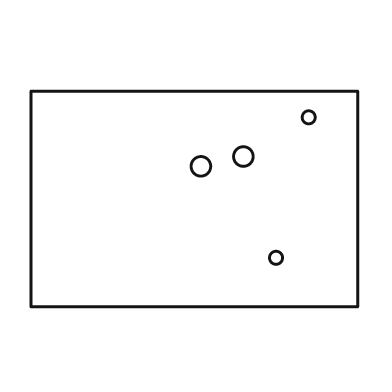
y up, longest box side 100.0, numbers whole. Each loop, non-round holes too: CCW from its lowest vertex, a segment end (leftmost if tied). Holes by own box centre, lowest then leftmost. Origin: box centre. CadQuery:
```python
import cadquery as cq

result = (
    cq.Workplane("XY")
    .moveTo(-50.0, -33.0)
    .lineTo(50.0, -33.0)
    .lineTo(50.0, 33.0)
    .lineTo(-50.0, 33.0)
    .close()
    .moveTo(25.0, -18.0)
    .circle(2.0)
    .moveTo(2.0, 10.0)
    .circle(3.0)
    .moveTo(15.0, 13.0)
    .circle(3.0)
    .moveTo(35.0, 25.0)
    .circle(2.0)
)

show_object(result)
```